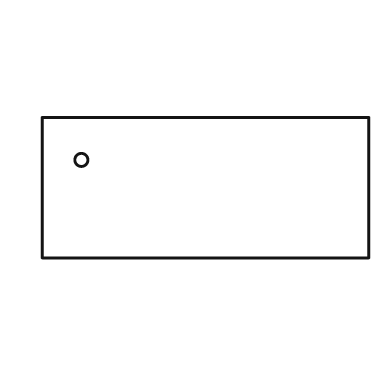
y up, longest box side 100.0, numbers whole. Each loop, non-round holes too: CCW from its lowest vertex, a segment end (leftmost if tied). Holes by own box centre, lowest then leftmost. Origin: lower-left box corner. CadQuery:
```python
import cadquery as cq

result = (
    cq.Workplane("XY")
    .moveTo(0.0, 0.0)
    .lineTo(100.0, 0.0)
    .lineTo(100.0, 43.0)
    .lineTo(0.0, 43.0)
    .close()
    .moveTo(12.0, 30.0)
    .circle(2.0)
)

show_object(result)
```